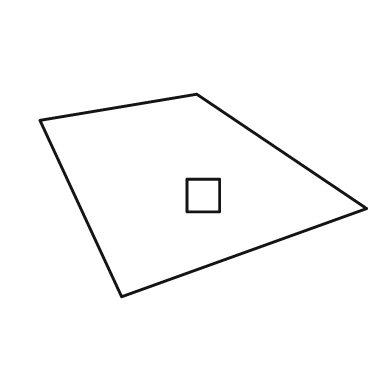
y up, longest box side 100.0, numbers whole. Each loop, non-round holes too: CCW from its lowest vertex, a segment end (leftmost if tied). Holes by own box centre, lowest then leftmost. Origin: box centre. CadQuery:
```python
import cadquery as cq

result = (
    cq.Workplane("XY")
    .moveTo(-25.0, -31.0)
    .lineTo(50.0, -4.0)
    .lineTo(-2.0, 31.0)
    .lineTo(-50.0, 23.0)
    .close()
    .moveTo(-5.0, -5.0)
    .lineTo(5.0, -5.0)
    .lineTo(5.0, 5.0)
    .lineTo(-5.0, 5.0)
    .close()
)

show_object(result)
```